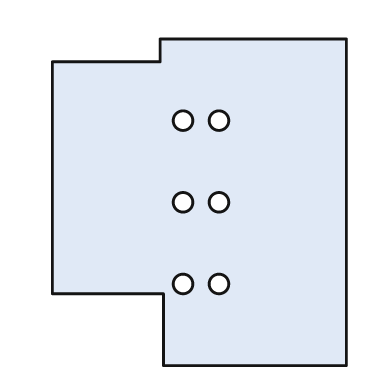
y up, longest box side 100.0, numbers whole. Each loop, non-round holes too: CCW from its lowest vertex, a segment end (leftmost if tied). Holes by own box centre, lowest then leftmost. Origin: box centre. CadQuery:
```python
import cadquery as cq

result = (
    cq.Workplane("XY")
    .moveTo(-11.0, -50.0)
    .lineTo(45.0, -50.0)
    .lineTo(45.0, 50.0)
    .lineTo(-12.0, 50.0)
    .lineTo(-12.0, 43.0)
    .lineTo(-45.0, 43.0)
    .lineTo(-45.0, -28.0)
    .lineTo(-11.0, -28.0)
    .close()
    .moveTo(-5.0, -25.0)
    .circle(3.0)
    .moveTo(6.0, -25.0)
    .circle(3.0)
    .moveTo(-5.0, 0.0)
    .circle(3.0)
    .moveTo(6.0, 0.0)
    .circle(3.0)
    .moveTo(-5.0, 25.0)
    .circle(3.0)
    .moveTo(6.0, 25.0)
    .circle(3.0)
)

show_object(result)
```